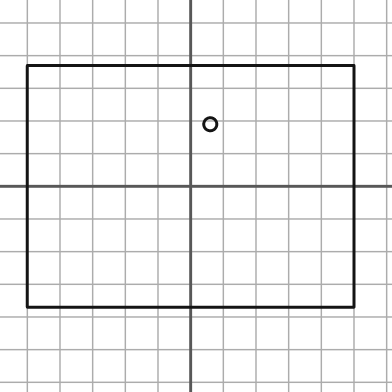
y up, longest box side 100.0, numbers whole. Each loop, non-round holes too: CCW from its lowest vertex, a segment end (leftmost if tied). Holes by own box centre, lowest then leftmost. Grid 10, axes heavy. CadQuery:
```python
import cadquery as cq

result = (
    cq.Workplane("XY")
    .moveTo(-50.0, -37.0)
    .lineTo(50.0, -37.0)
    .lineTo(50.0, 37.0)
    .lineTo(-50.0, 37.0)
    .close()
    .moveTo(6.0, 19.0)
    .circle(2.0)
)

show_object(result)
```